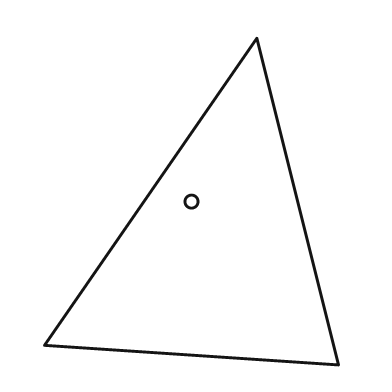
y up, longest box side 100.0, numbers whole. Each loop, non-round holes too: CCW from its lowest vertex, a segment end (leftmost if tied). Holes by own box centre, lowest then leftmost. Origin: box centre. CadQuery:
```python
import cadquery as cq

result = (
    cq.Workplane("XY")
    .moveTo(45.0, -50.0)
    .lineTo(20.0, 50.0)
    .lineTo(-45.0, -44.0)
    .close()
    .moveTo(0.0, 0.0)
    .circle(2.0)
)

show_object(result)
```